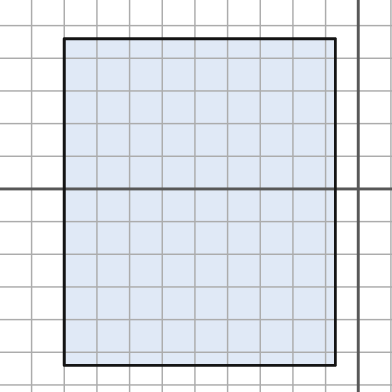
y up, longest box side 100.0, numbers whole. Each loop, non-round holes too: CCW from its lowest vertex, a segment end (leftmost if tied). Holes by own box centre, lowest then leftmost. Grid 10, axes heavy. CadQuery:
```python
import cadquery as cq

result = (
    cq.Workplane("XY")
    .moveTo(-90.0, -54.0)
    .lineTo(-7.0, -54.0)
    .lineTo(-7.0, 46.0)
    .lineTo(-90.0, 46.0)
    .close()
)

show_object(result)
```